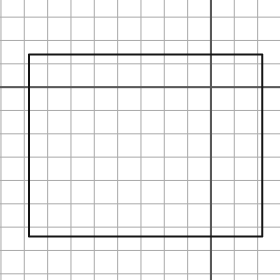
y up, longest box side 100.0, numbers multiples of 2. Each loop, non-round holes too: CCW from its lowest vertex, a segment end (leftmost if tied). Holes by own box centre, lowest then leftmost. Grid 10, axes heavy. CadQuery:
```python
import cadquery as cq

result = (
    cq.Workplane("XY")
    .moveTo(-78.0, -64.0)
    .lineTo(22.0, -64.0)
    .lineTo(22.0, 14.0)
    .lineTo(-78.0, 14.0)
    .close()
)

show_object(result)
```